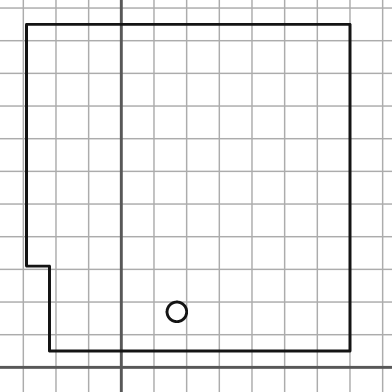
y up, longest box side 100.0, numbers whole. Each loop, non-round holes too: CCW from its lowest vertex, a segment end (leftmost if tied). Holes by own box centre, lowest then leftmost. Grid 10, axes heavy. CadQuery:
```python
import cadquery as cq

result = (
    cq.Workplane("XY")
    .moveTo(-22.0, 5.0)
    .lineTo(70.0, 5.0)
    .lineTo(70.0, 105.0)
    .lineTo(-29.0, 105.0)
    .lineTo(-29.0, 31.0)
    .lineTo(-22.0, 31.0)
    .close()
    .moveTo(17.0, 17.0)
    .circle(3.0)
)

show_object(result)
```